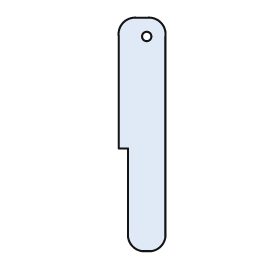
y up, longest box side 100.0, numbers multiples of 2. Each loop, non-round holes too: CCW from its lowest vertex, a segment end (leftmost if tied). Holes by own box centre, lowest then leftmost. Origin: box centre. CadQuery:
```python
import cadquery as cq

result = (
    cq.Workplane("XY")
    .moveTo(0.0, -50.0)
    .lineTo(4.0, -50.0)
    .threePointArc((8.0, -48.0), (10.0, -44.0))
    .lineTo(10.0, 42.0)
    .threePointArc((8.0, 48.0), (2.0, 50.0))
    .lineTo(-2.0, 50.0)
    .threePointArc((-8.0, 48.0), (-10.0, 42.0))
    .lineTo(-10.0, -6.0)
    .lineTo(-6.0, -6.0)
    .lineTo(-6.0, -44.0)
    .threePointArc((-4.0, -48.0), (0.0, -50.0))
    .close()
    .moveTo(2.0, 42.0)
    .circle(2.0)
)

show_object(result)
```